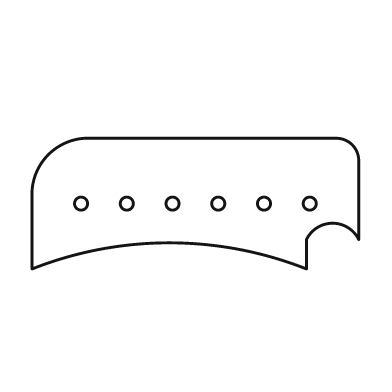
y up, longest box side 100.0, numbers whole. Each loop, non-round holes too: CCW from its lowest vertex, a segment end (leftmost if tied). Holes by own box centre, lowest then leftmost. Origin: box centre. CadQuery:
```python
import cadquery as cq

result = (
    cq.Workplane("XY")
    .moveTo(-50.0, -20.0)
    .threePointArc((-8.0, -12.0), (34.0, -20.0))
    .lineTo(34.0, -11.0)
    .threePointArc((42.0, -6.0), (50.0, -11.0))
    .lineTo(50.0, 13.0)
    .threePointArc((48.0, 18.0), (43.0, 20.0))
    .lineTo(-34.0, 20.0)
    .threePointArc((-45.0, 15.0), (-50.0, 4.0))
    .close()
    .moveTo(-35.0, 0.0)
    .circle(2.0)
    .moveTo(-21.0, 0.0)
    .circle(2.0)
    .moveTo(-7.0, 0.0)
    .circle(2.0)
    .moveTo(7.0, 0.0)
    .circle(2.0)
    .moveTo(21.0, 0.0)
    .circle(2.0)
    .moveTo(35.0, 0.0)
    .circle(2.0)
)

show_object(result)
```